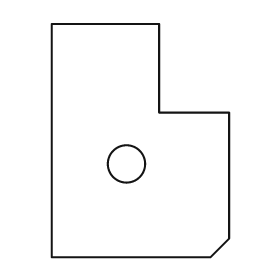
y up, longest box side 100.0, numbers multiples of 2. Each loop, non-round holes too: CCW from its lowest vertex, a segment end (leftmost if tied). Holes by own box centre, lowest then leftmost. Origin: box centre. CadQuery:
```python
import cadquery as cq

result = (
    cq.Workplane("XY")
    .moveTo(-38.0, -50.0)
    .lineTo(30.0, -50.0)
    .lineTo(38.0, -42.0)
    .lineTo(38.0, 12.0)
    .lineTo(8.0, 12.0)
    .lineTo(8.0, 50.0)
    .lineTo(-38.0, 50.0)
    .close()
    .moveTo(-6.0, -10.0)
    .circle(8.0)
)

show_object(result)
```